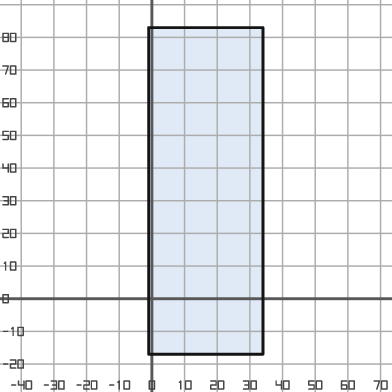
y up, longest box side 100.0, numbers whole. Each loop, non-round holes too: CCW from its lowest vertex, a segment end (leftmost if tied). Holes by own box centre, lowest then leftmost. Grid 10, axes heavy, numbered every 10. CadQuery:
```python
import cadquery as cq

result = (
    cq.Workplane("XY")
    .moveTo(-1.0, -17.0)
    .lineTo(34.0, -17.0)
    .lineTo(34.0, 83.0)
    .lineTo(-1.0, 83.0)
    .close()
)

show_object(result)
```